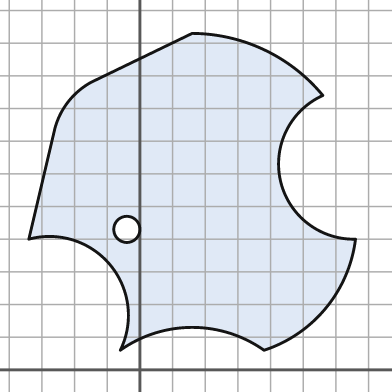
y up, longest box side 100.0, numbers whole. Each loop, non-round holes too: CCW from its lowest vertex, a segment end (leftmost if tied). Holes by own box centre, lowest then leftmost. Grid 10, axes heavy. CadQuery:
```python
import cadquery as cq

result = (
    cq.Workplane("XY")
    .moveTo(-6.0, 6.0)
    .threePointArc((16.0, 13.0), (38.0, 6.0))
    .threePointArc((57.0, 19.0), (66.0, 40.0))
    .threePointArc((43.0, 58.0), (56.0, 84.0))
    .threePointArc((38.0, 98.0), (16.0, 103.0))
    .lineTo(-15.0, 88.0)
    .threePointArc((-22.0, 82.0), (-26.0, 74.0))
    .lineTo(-34.0, 40.0)
    .threePointArc((-9.0, 32.0), (-6.0, 6.0))
    .close()
    .moveTo(-4.0, 43.0)
    .circle(4.0)
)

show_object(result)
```